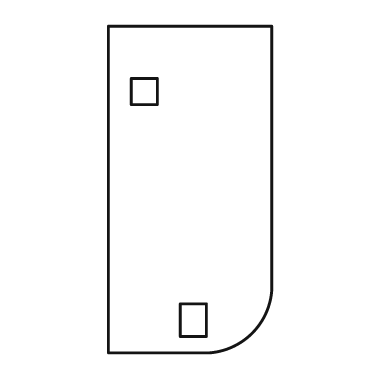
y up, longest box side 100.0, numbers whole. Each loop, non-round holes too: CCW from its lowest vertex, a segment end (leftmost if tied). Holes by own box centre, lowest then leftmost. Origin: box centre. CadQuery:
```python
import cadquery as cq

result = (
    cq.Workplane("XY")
    .moveTo(-25.0, -50.0)
    .lineTo(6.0, -50.0)
    .threePointArc((19.0, -44.0), (25.0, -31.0))
    .lineTo(25.0, 50.0)
    .lineTo(-25.0, 50.0)
    .close()
    .moveTo(-3.0, -45.0)
    .lineTo(5.0, -45.0)
    .lineTo(5.0, -35.0)
    .lineTo(-3.0, -35.0)
    .close()
    .moveTo(-18.0, 26.0)
    .lineTo(-10.0, 26.0)
    .lineTo(-10.0, 34.0)
    .lineTo(-18.0, 34.0)
    .close()
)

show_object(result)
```